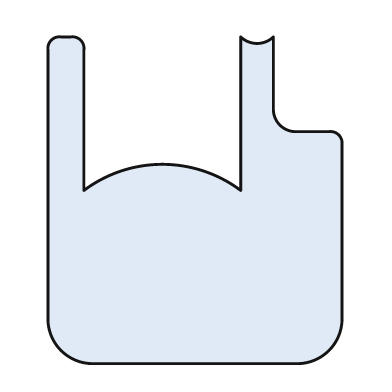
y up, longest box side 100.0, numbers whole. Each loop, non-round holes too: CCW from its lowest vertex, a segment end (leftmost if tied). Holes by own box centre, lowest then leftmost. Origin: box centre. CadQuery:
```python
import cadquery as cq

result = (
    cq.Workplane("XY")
    .moveTo(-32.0, -50.0)
    .lineTo(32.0, -50.0)
    .threePointArc((41.0, -46.0), (45.0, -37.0))
    .lineTo(45.0, 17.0)
    .threePointArc((44.0, 20.0), (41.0, 21.0))
    .lineTo(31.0, 21.0)
    .threePointArc((26.0, 23.0), (24.0, 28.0))
    .lineTo(24.0, 50.0)
    .threePointArc((19.0, 48.0), (14.0, 50.0))
    .lineTo(14.0, 3.0)
    .threePointArc((-10.0, 11.0), (-34.0, 3.0))
    .lineTo(-34.0, 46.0)
    .threePointArc((-35.0, 49.0), (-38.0, 50.0))
    .lineTo(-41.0, 50.0)
    .threePointArc((-44.0, 49.0), (-45.0, 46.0))
    .lineTo(-45.0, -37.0)
    .threePointArc((-41.0, -46.0), (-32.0, -50.0))
    .close()
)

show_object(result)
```